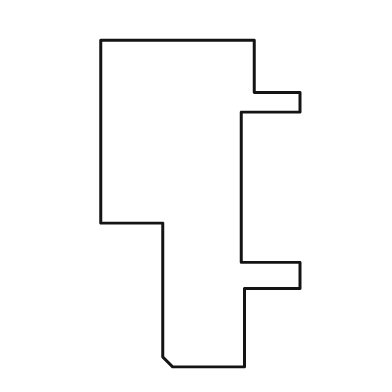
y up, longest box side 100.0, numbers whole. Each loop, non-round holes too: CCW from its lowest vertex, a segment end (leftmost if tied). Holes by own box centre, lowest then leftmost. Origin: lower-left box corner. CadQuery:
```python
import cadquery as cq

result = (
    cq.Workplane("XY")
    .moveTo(22.0, 0.0)
    .lineTo(44.0, 0.0)
    .lineTo(44.0, 24.0)
    .lineTo(61.0, 24.0)
    .lineTo(61.0, 32.0)
    .lineTo(43.0, 32.0)
    .lineTo(43.0, 78.0)
    .lineTo(61.0, 78.0)
    .lineTo(61.0, 84.0)
    .lineTo(47.0, 84.0)
    .lineTo(47.0, 100.0)
    .lineTo(0.0, 100.0)
    .lineTo(0.0, 44.0)
    .lineTo(19.0, 44.0)
    .lineTo(19.0, 3.0)
    .close()
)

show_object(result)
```